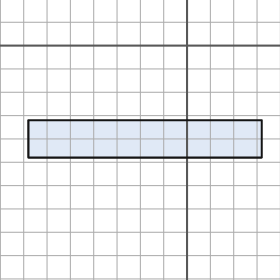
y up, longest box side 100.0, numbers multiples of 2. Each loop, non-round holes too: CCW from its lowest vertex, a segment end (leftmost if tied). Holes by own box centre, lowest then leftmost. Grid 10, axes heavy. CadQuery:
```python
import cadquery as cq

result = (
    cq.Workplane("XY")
    .moveTo(-68.0, -48.0)
    .lineTo(32.0, -48.0)
    .lineTo(32.0, -32.0)
    .lineTo(-68.0, -32.0)
    .close()
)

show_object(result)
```